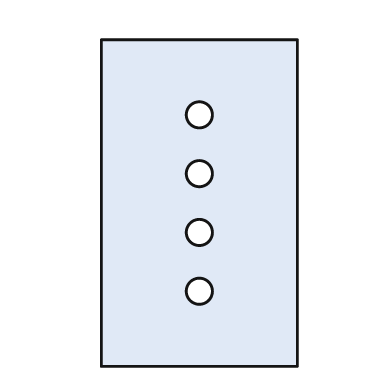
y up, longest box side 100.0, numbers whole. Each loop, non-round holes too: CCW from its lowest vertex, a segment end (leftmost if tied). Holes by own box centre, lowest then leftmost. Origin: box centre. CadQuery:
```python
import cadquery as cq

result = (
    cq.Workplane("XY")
    .moveTo(-30.0, -50.0)
    .lineTo(30.0, -50.0)
    .lineTo(30.0, 50.0)
    .lineTo(-30.0, 50.0)
    .close()
    .moveTo(0.0, -27.0)
    .circle(4.0)
    .moveTo(0.0, -9.0)
    .circle(4.0)
    .moveTo(0.0, 9.0)
    .circle(4.0)
    .moveTo(0.0, 27.0)
    .circle(4.0)
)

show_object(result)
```